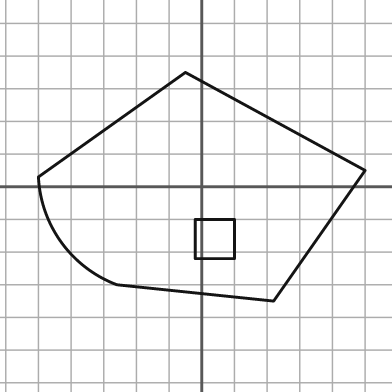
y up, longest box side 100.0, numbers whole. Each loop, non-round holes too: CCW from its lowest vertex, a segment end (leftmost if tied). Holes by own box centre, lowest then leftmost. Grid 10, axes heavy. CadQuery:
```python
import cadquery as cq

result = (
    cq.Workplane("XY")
    .moveTo(22.0, -35.0)
    .lineTo(50.0, 5.0)
    .lineTo(-5.0, 35.0)
    .lineTo(-50.0, 3.0)
    .threePointArc((-43.0, -17.0), (-26.0, -30.0))
    .close()
    .moveTo(-2.0, -22.0)
    .lineTo(10.0, -22.0)
    .lineTo(10.0, -10.0)
    .lineTo(-2.0, -10.0)
    .close()
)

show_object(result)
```